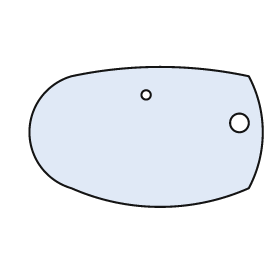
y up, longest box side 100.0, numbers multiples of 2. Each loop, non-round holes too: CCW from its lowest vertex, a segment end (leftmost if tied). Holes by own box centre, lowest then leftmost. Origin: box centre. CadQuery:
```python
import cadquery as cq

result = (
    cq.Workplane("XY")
    .moveTo(-32.0, -22.0)
    .threePointArc((6.0, -30.0), (44.0, -22.0))
    .threePointArc((50.0, 2.0), (44.0, 26.0))
    .threePointArc((6.0, 30.0), (-32.0, 26.0))
    .threePointArc((-50.0, 2.0), (-32.0, -22.0))
    .close()
    .moveTo(40.0, 6.0)
    .circle(4.0)
    .moveTo(0.0, 18.0)
    .circle(2.0)
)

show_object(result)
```